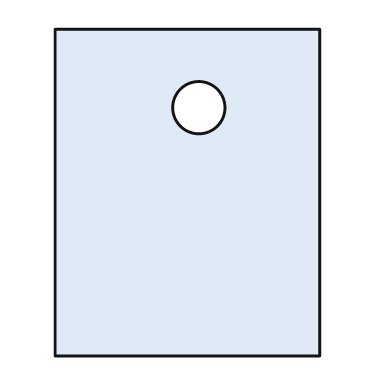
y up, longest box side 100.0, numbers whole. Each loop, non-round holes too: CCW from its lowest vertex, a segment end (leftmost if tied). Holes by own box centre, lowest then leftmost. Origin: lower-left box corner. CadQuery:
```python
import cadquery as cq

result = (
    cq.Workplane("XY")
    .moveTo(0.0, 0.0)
    .lineTo(81.0, 0.0)
    .lineTo(81.0, 100.0)
    .lineTo(0.0, 100.0)
    .close()
    .moveTo(44.0, 76.0)
    .circle(8.0)
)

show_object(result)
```